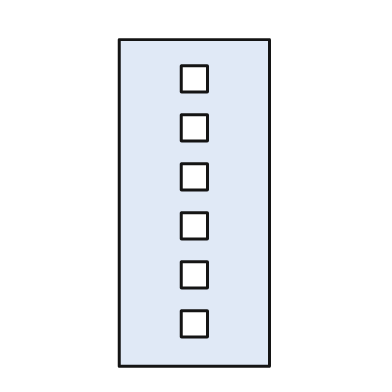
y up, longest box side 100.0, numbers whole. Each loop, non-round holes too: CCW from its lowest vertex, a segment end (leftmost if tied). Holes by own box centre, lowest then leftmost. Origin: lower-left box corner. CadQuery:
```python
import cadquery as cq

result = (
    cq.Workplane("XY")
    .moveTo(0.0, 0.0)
    .lineTo(46.0, 0.0)
    .lineTo(46.0, 100.0)
    .lineTo(0.0, 100.0)
    .close()
    .moveTo(19.0, 9.0)
    .lineTo(27.0, 9.0)
    .lineTo(27.0, 17.0)
    .lineTo(19.0, 17.0)
    .close()
    .moveTo(19.0, 24.0)
    .lineTo(27.0, 24.0)
    .lineTo(27.0, 32.0)
    .lineTo(19.0, 32.0)
    .close()
    .moveTo(19.0, 39.0)
    .lineTo(27.0, 39.0)
    .lineTo(27.0, 47.0)
    .lineTo(19.0, 47.0)
    .close()
    .moveTo(19.0, 54.0)
    .lineTo(27.0, 54.0)
    .lineTo(27.0, 62.0)
    .lineTo(19.0, 62.0)
    .close()
    .moveTo(19.0, 69.0)
    .lineTo(27.0, 69.0)
    .lineTo(27.0, 77.0)
    .lineTo(19.0, 77.0)
    .close()
    .moveTo(19.0, 84.0)
    .lineTo(27.0, 84.0)
    .lineTo(27.0, 92.0)
    .lineTo(19.0, 92.0)
    .close()
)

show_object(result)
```